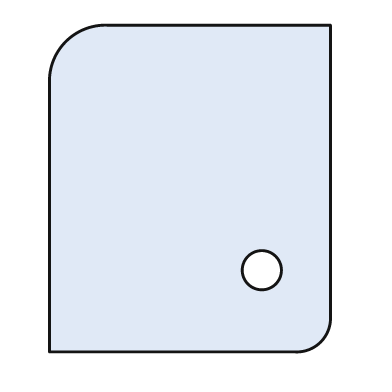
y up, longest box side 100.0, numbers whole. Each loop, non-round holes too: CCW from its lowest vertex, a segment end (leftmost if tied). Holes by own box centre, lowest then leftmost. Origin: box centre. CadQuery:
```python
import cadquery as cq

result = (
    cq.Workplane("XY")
    .moveTo(-43.0, -50.0)
    .lineTo(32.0, -50.0)
    .threePointArc((40.0, -47.0), (43.0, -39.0))
    .lineTo(43.0, 50.0)
    .lineTo(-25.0, 50.0)
    .threePointArc((-38.0, 45.0), (-43.0, 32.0))
    .close()
    .moveTo(22.0, -25.0)
    .circle(6.0)
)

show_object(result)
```